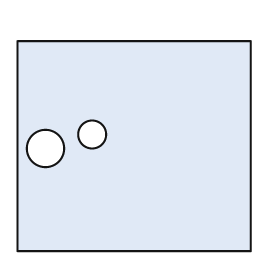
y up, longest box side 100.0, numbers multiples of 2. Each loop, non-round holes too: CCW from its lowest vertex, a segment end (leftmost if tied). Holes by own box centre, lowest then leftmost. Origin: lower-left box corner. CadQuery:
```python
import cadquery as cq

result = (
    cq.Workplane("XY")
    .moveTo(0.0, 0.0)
    .lineTo(100.0, 0.0)
    .lineTo(100.0, 90.0)
    .lineTo(0.0, 90.0)
    .close()
    .moveTo(12.0, 44.0)
    .circle(8.0)
    .moveTo(32.0, 50.0)
    .circle(6.0)
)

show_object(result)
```